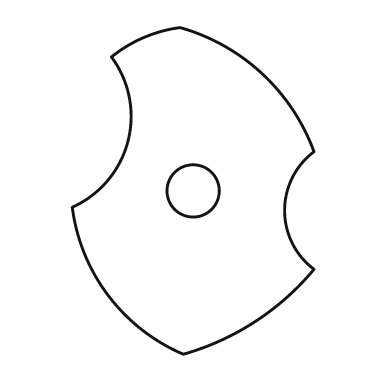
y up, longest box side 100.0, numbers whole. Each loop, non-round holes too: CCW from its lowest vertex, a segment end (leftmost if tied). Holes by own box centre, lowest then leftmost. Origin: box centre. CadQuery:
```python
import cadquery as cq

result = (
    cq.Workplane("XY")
    .moveTo(-3.0, -50.0)
    .threePointArc((19.0, -40.0), (37.0, -24.0))
    .threePointArc((28.0, -6.0), (37.0, 12.0))
    .threePointArc((21.0, 36.0), (-4.0, 50.0))
    .threePointArc((-15.0, 47.0), (-25.0, 41.0))
    .threePointArc((-20.0, 15.0), (-37.0, -5.0))
    .threePointArc((-26.0, -32.0), (-3.0, -50.0))
    .close()
    .moveTo(0.0, 0.0)
    .circle(8.0)
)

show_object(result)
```